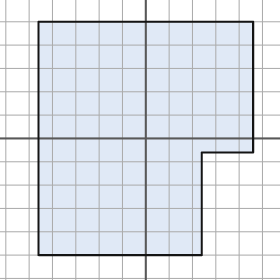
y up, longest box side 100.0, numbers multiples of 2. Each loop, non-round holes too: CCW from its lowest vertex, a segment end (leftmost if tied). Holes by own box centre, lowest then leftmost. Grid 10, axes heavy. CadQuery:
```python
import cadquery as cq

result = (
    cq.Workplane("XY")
    .moveTo(-46.0, -50.0)
    .lineTo(24.0, -50.0)
    .lineTo(24.0, -6.0)
    .lineTo(46.0, -6.0)
    .lineTo(46.0, 50.0)
    .lineTo(-46.0, 50.0)
    .close()
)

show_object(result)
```